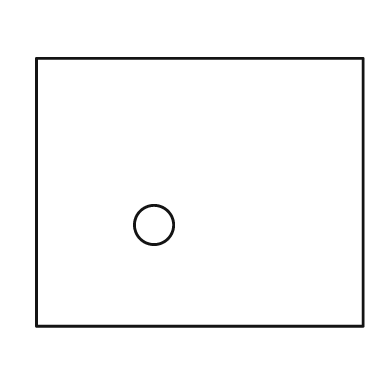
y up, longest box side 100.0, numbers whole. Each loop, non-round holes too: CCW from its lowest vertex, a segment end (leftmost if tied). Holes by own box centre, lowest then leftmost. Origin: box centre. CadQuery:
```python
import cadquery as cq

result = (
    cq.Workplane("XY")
    .moveTo(-50.0, -41.0)
    .lineTo(50.0, -41.0)
    .lineTo(50.0, 41.0)
    .lineTo(-50.0, 41.0)
    .close()
    .moveTo(-14.0, -10.0)
    .circle(6.0)
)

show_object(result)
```